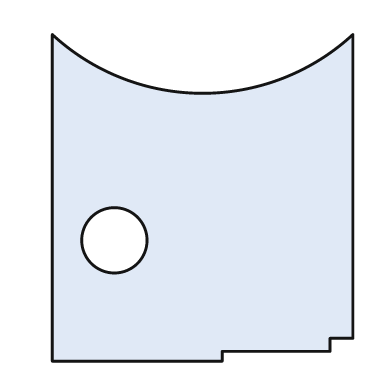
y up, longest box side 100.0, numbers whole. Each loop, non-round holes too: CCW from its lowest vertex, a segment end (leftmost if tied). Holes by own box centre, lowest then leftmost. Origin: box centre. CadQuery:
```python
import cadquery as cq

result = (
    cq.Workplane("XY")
    .moveTo(-46.0, -50.0)
    .lineTo(6.0, -50.0)
    .lineTo(6.0, -47.0)
    .lineTo(39.0, -47.0)
    .lineTo(39.0, -43.0)
    .lineTo(46.0, -43.0)
    .lineTo(46.0, 50.0)
    .threePointArc((0.0, 32.0), (-46.0, 50.0))
    .close()
    .moveTo(-27.0, -13.0)
    .circle(10.0)
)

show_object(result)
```